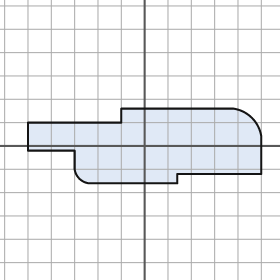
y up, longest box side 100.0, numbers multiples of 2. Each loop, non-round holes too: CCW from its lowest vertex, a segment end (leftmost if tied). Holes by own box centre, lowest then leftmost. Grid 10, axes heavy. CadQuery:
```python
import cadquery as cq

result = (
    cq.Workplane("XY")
    .moveTo(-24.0, -16.0)
    .lineTo(14.0, -16.0)
    .lineTo(14.0, -12.0)
    .lineTo(50.0, -12.0)
    .lineTo(50.0, 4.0)
    .threePointArc((46.0, 12.0), (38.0, 16.0))
    .lineTo(-10.0, 16.0)
    .lineTo(-10.0, 10.0)
    .lineTo(-50.0, 10.0)
    .lineTo(-50.0, -2.0)
    .lineTo(-30.0, -2.0)
    .lineTo(-30.0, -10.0)
    .threePointArc((-28.0, -14.0), (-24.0, -16.0))
    .close()
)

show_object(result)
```